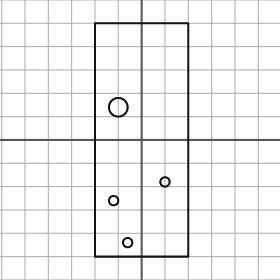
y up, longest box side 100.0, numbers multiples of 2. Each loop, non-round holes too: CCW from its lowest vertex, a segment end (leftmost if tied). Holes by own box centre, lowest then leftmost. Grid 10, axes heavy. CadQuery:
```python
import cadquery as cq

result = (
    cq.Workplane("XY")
    .moveTo(-20.0, -50.0)
    .lineTo(20.0, -50.0)
    .lineTo(20.0, 50.0)
    .lineTo(-20.0, 50.0)
    .close()
    .moveTo(-6.0, -44.0)
    .circle(2.0)
    .moveTo(-12.0, -26.0)
    .circle(2.0)
    .moveTo(10.0, -18.0)
    .circle(2.0)
    .moveTo(-10.0, 14.0)
    .circle(4.0)
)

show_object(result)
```